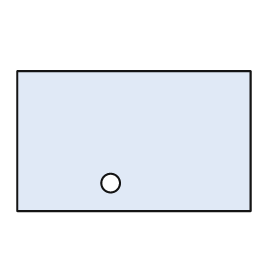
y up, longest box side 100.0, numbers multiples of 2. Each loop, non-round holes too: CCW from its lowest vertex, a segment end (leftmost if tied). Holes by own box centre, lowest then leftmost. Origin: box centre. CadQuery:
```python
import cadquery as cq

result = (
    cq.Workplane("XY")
    .moveTo(-50.0, -30.0)
    .lineTo(50.0, -30.0)
    .lineTo(50.0, 30.0)
    .lineTo(-50.0, 30.0)
    .close()
    .moveTo(-10.0, -18.0)
    .circle(4.0)
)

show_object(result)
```